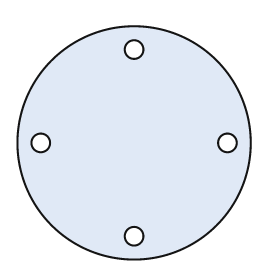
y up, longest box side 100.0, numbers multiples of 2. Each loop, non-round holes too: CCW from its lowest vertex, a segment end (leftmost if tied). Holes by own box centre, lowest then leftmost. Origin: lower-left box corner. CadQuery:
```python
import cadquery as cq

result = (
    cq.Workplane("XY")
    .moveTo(50.0, 50.0)
    .circle(50.0)
    .moveTo(50.0, 10.0)
    .circle(4.0)
    .moveTo(10.0, 50.0)
    .circle(4.0)
    .moveTo(90.0, 50.0)
    .circle(4.0)
    .moveTo(50.0, 90.0)
    .circle(4.0)
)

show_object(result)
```